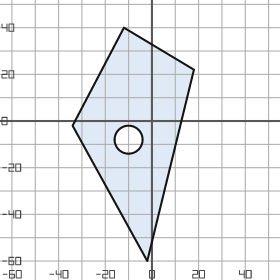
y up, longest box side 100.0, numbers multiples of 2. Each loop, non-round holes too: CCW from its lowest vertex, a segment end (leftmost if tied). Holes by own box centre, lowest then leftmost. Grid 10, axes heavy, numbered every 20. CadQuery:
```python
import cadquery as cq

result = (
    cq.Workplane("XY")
    .moveTo(-2.0, -60.0)
    .lineTo(18.0, 22.0)
    .lineTo(-12.0, 40.0)
    .lineTo(-34.0, -2.0)
    .close()
    .moveTo(-10.0, -8.0)
    .circle(6.0)
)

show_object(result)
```